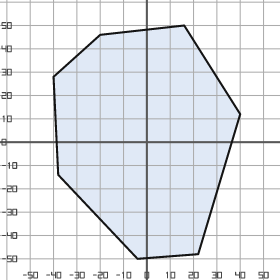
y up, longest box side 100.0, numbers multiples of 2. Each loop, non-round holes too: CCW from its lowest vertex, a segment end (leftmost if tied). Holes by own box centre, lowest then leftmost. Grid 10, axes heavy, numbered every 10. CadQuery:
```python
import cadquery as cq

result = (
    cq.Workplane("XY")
    .moveTo(-4.0, -50.0)
    .lineTo(22.0, -48.0)
    .lineTo(40.0, 12.0)
    .lineTo(16.0, 50.0)
    .lineTo(-20.0, 46.0)
    .lineTo(-40.0, 28.0)
    .lineTo(-38.0, -14.0)
    .close()
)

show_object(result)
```